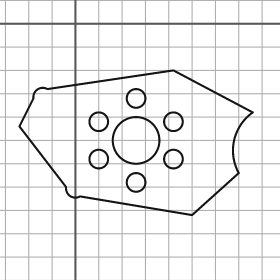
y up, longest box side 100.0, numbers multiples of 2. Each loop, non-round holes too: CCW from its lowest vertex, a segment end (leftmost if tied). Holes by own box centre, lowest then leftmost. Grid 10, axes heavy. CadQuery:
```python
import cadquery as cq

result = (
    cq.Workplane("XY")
    .moveTo(50.0, -82.0)
    .lineTo(70.0, -64.0)
    .threePointArc((68.0, -50.0), (76.0, -38.0))
    .lineTo(42.0, -20.0)
    .lineTo(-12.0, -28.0)
    .threePointArc((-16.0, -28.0), (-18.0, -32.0))
    .lineTo(-24.0, -44.0)
    .lineTo(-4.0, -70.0)
    .threePointArc((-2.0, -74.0), (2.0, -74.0))
    .close()
    .moveTo(26.0, -68.0)
    .circle(4.0)
    .moveTo(10.0, -58.0)
    .circle(4.0)
    .moveTo(42.0, -58.0)
    .circle(4.0)
    .moveTo(26.0, -50.0)
    .circle(10.0)
    .moveTo(10.0, -42.0)
    .circle(4.0)
    .moveTo(42.0, -42.0)
    .circle(4.0)
    .moveTo(26.0, -32.0)
    .circle(4.0)
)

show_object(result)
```